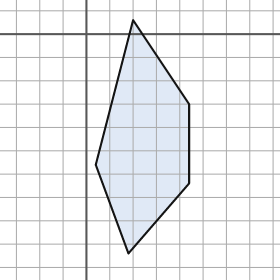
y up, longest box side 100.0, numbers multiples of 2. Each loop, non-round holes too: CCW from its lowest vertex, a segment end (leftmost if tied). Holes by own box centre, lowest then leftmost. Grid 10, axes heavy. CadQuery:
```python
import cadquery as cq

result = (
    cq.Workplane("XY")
    .moveTo(18.0, -94.0)
    .lineTo(44.0, -64.0)
    .lineTo(44.0, -30.0)
    .lineTo(20.0, 6.0)
    .lineTo(4.0, -56.0)
    .close()
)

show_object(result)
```